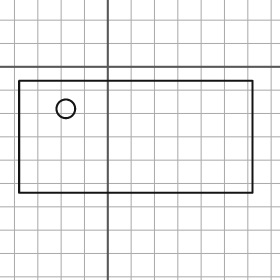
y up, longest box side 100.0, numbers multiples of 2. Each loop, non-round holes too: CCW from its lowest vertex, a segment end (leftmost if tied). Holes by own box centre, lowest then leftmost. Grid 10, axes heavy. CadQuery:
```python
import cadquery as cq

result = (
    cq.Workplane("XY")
    .moveTo(-38.0, -54.0)
    .lineTo(62.0, -54.0)
    .lineTo(62.0, -6.0)
    .lineTo(-38.0, -6.0)
    .close()
    .moveTo(-18.0, -18.0)
    .circle(4.0)
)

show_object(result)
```